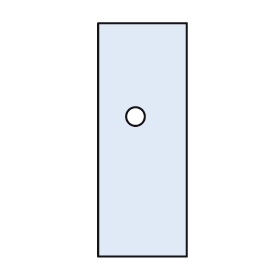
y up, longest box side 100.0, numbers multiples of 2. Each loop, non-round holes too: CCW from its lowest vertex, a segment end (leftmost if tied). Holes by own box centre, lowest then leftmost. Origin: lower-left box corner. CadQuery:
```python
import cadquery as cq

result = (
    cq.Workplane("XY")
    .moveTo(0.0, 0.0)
    .lineTo(38.0, 0.0)
    .lineTo(38.0, 100.0)
    .lineTo(0.0, 100.0)
    .close()
    .moveTo(16.0, 60.0)
    .circle(4.0)
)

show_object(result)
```